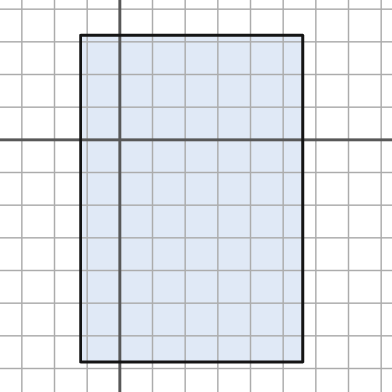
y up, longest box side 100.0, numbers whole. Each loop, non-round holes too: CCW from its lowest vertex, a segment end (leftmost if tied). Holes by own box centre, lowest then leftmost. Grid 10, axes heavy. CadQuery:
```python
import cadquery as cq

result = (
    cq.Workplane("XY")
    .moveTo(-12.0, -68.0)
    .lineTo(56.0, -68.0)
    .lineTo(56.0, 32.0)
    .lineTo(-12.0, 32.0)
    .close()
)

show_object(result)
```